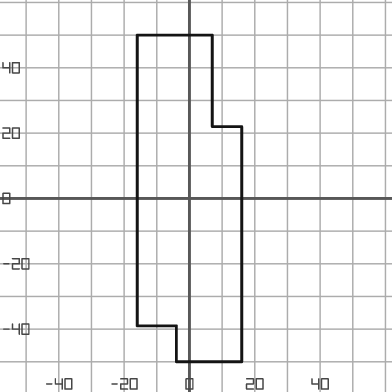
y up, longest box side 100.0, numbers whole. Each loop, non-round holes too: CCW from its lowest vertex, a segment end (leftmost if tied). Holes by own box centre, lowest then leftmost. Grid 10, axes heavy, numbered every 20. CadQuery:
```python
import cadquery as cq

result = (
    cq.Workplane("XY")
    .moveTo(-4.0, -50.0)
    .lineTo(16.0, -50.0)
    .lineTo(16.0, 22.0)
    .lineTo(7.0, 22.0)
    .lineTo(7.0, 50.0)
    .lineTo(-16.0, 50.0)
    .lineTo(-16.0, -39.0)
    .lineTo(-4.0, -39.0)
    .close()
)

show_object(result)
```